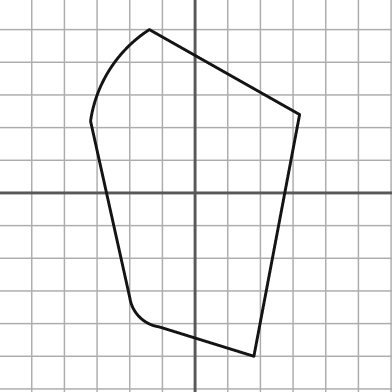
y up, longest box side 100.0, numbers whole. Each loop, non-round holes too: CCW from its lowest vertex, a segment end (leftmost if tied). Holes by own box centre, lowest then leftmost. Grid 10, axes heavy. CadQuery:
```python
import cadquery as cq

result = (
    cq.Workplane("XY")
    .moveTo(18.0, -50.0)
    .lineTo(32.0, 24.0)
    .lineTo(-14.0, 50.0)
    .threePointArc((-26.0, 38.0), (-32.0, 22.0))
    .lineTo(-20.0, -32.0)
    .threePointArc((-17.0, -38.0), (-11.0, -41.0))
    .close()
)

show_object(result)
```